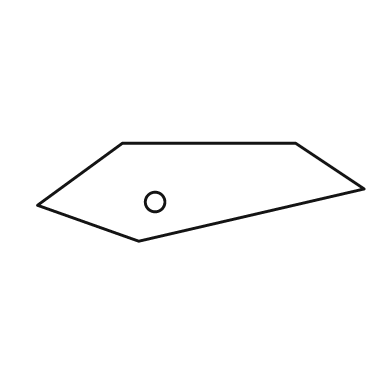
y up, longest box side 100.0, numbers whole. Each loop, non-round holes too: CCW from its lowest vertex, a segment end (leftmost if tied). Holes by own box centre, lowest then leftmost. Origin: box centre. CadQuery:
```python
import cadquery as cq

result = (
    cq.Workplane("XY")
    .moveTo(-19.0, -15.0)
    .lineTo(50.0, 1.0)
    .lineTo(29.0, 15.0)
    .lineTo(-24.0, 15.0)
    .lineTo(-50.0, -4.0)
    .close()
    .moveTo(-14.0, -3.0)
    .circle(3.0)
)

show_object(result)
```